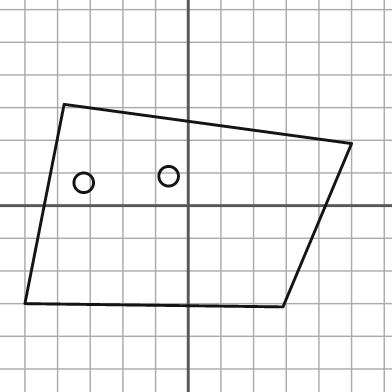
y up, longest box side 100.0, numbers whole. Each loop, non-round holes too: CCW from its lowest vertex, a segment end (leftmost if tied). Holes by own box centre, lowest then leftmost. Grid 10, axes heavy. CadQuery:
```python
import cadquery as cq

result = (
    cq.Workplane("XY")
    .moveTo(29.0, -31.0)
    .lineTo(50.0, 19.0)
    .lineTo(-38.0, 31.0)
    .lineTo(-50.0, -30.0)
    .close()
    .moveTo(-32.0, 7.0)
    .circle(3.0)
    .moveTo(-6.0, 9.0)
    .circle(3.0)
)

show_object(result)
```